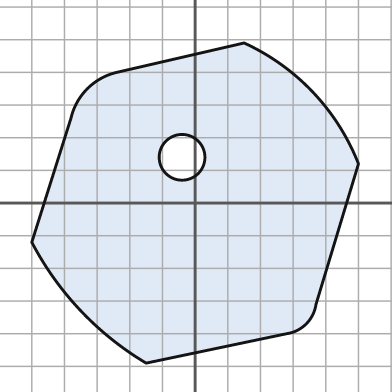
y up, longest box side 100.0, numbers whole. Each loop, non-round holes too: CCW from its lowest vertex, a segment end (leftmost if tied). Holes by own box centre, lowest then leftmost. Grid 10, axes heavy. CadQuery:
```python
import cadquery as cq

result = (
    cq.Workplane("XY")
    .moveTo(-15.0, -49.0)
    .lineTo(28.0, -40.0)
    .threePointArc((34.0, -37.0), (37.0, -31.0))
    .lineTo(50.0, 12.0)
    .threePointArc((36.0, 34.0), (15.0, 49.0))
    .lineTo(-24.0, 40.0)
    .threePointArc((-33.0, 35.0), (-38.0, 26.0))
    .lineTo(-50.0, -12.0)
    .threePointArc((-35.0, -33.0), (-15.0, -49.0))
    .close()
    .moveTo(-4.0, 14.0)
    .circle(7.0)
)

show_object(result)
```